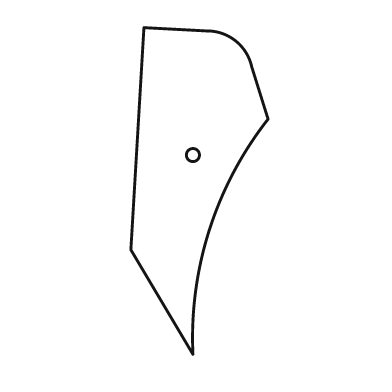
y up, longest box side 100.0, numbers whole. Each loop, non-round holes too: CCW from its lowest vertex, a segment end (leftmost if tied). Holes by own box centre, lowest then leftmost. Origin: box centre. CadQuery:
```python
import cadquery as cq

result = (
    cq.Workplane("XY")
    .moveTo(-2.0, -50.0)
    .threePointArc((3.0, -12.0), (21.0, 22.0))
    .lineTo(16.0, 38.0)
    .threePointArc((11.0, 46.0), (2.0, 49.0))
    .lineTo(-17.0, 50.0)
    .lineTo(-21.0, -18.0)
    .close()
    .moveTo(-2.0, 11.0)
    .circle(2.0)
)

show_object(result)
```